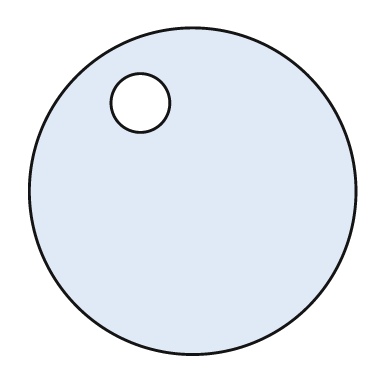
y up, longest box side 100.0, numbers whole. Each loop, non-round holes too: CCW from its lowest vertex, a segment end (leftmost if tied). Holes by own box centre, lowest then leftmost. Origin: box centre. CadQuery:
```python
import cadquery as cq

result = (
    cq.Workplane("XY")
    .moveTo(0.0, 0.0)
    .circle(50.0)
    .moveTo(-16.0, 27.0)
    .circle(9.0)
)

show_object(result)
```